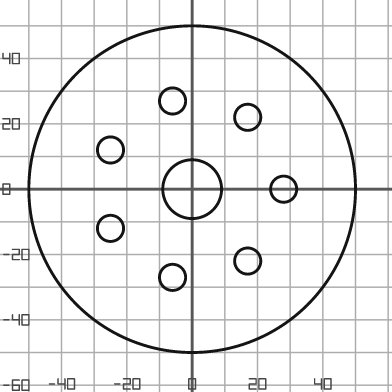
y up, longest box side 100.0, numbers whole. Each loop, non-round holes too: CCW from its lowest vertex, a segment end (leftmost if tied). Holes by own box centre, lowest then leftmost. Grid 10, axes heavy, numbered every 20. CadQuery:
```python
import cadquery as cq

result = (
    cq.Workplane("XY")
    .moveTo(0.0, 0.0)
    .circle(50.0)
    .moveTo(-6.0, -27.0)
    .circle(4.0)
    .moveTo(17.0, -22.0)
    .circle(4.0)
    .moveTo(-25.0, -12.0)
    .circle(4.0)
    .moveTo(0.0, 0.0)
    .circle(9.0)
    .moveTo(28.0, 0.0)
    .circle(4.0)
    .moveTo(-25.0, 12.0)
    .circle(4.0)
    .moveTo(17.0, 22.0)
    .circle(4.0)
    .moveTo(-6.0, 27.0)
    .circle(4.0)
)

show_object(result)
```